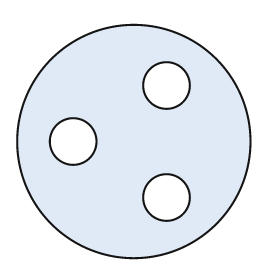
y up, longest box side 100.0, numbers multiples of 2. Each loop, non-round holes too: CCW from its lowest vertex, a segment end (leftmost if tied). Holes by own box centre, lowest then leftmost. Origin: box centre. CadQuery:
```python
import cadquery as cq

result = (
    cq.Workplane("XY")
    .moveTo(0.0, 0.0)
    .circle(50.0)
    .moveTo(14.0, -24.0)
    .circle(10.0)
    .moveTo(-26.0, 0.0)
    .circle(10.0)
    .moveTo(14.0, 24.0)
    .circle(10.0)
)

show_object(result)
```